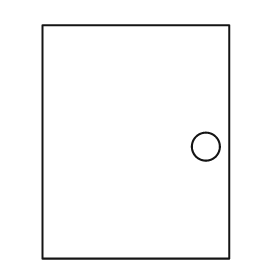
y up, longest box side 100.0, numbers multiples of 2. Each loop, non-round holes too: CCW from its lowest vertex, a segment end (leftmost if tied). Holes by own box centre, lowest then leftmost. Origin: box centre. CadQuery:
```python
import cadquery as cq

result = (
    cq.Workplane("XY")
    .moveTo(-40.0, -50.0)
    .lineTo(40.0, -50.0)
    .lineTo(40.0, 50.0)
    .lineTo(-40.0, 50.0)
    .close()
    .moveTo(30.0, -2.0)
    .circle(6.0)
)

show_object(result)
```